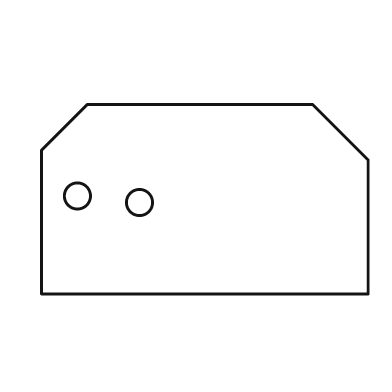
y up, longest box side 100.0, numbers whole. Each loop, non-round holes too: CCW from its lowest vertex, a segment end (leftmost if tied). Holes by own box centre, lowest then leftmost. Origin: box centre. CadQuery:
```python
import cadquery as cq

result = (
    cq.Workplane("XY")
    .moveTo(-50.0, -29.0)
    .lineTo(50.0, -29.0)
    .lineTo(50.0, 12.0)
    .lineTo(33.0, 29.0)
    .lineTo(-36.0, 29.0)
    .lineTo(-50.0, 15.0)
    .close()
    .moveTo(-20.0, -1.0)
    .circle(4.0)
    .moveTo(-39.0, 1.0)
    .circle(4.0)
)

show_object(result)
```